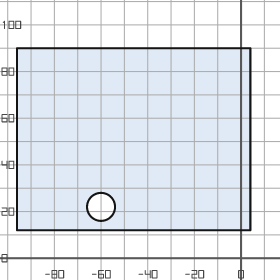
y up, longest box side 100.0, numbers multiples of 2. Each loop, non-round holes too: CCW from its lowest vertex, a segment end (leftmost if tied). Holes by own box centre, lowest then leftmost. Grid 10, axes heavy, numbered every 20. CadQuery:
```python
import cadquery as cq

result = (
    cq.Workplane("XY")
    .moveTo(-96.0, 12.0)
    .lineTo(4.0, 12.0)
    .lineTo(4.0, 90.0)
    .lineTo(-96.0, 90.0)
    .close()
    .moveTo(-60.0, 22.0)
    .circle(6.0)
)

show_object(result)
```